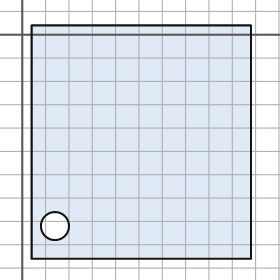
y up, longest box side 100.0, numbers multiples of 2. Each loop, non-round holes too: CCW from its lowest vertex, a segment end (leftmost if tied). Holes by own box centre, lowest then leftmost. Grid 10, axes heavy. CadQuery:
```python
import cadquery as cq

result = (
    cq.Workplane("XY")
    .moveTo(4.0, -96.0)
    .lineTo(98.0, -96.0)
    .lineTo(98.0, 4.0)
    .lineTo(4.0, 4.0)
    .close()
    .moveTo(14.0, -82.0)
    .circle(6.0)
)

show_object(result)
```